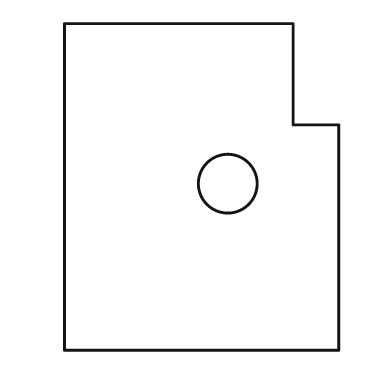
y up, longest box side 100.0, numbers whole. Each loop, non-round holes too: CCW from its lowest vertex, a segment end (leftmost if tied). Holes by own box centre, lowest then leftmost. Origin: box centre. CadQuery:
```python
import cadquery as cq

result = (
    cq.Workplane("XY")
    .moveTo(-42.0, -50.0)
    .lineTo(42.0, -50.0)
    .lineTo(42.0, 19.0)
    .lineTo(28.0, 19.0)
    .lineTo(28.0, 50.0)
    .lineTo(-42.0, 50.0)
    .close()
    .moveTo(8.0, 1.0)
    .circle(9.0)
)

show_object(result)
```